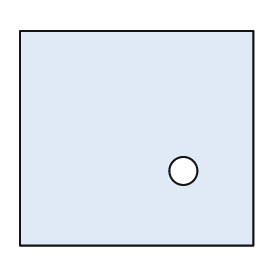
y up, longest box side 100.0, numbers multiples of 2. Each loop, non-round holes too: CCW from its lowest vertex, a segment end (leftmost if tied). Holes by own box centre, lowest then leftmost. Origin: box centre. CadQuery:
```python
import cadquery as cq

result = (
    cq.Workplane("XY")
    .moveTo(-50.0, -46.0)
    .lineTo(50.0, -46.0)
    .lineTo(50.0, 46.0)
    .lineTo(-50.0, 46.0)
    .close()
    .moveTo(20.0, -14.0)
    .circle(6.0)
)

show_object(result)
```